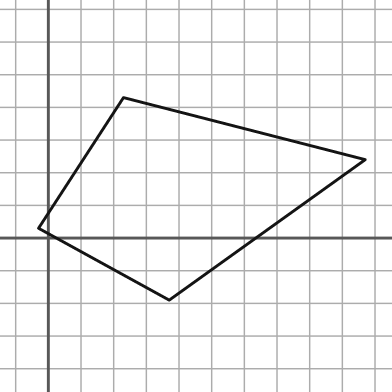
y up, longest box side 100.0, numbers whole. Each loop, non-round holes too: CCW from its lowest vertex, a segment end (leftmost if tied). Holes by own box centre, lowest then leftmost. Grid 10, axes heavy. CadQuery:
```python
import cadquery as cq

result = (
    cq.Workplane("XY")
    .moveTo(37.0, -19.0)
    .lineTo(97.0, 24.0)
    .lineTo(23.0, 43.0)
    .lineTo(-3.0, 3.0)
    .close()
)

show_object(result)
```